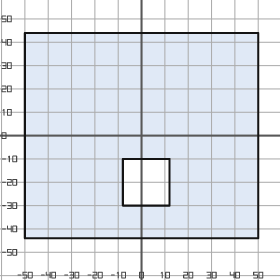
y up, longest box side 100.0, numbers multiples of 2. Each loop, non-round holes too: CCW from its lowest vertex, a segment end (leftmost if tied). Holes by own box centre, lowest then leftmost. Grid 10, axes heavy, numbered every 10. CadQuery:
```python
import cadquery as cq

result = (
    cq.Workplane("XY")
    .moveTo(-50.0, -44.0)
    .lineTo(50.0, -44.0)
    .lineTo(50.0, 44.0)
    .lineTo(-50.0, 44.0)
    .close()
    .moveTo(-8.0, -30.0)
    .lineTo(12.0, -30.0)
    .lineTo(12.0, -10.0)
    .lineTo(-8.0, -10.0)
    .close()
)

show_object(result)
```